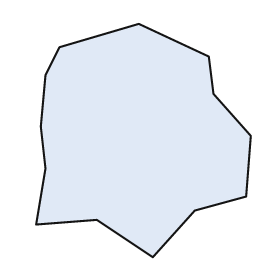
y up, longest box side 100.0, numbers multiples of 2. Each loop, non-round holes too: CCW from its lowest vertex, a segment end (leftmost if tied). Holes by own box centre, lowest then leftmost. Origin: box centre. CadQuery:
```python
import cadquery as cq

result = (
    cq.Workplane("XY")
    .moveTo(4.0, -50.0)
    .lineTo(22.0, -30.0)
    .lineTo(44.0, -24.0)
    .lineTo(46.0, 2.0)
    .lineTo(30.0, 20.0)
    .lineTo(28.0, 36.0)
    .lineTo(-2.0, 50.0)
    .lineTo(-36.0, 40.0)
    .lineTo(-42.0, 28.0)
    .lineTo(-44.0, 6.0)
    .lineTo(-42.0, -12.0)
    .lineTo(-46.0, -36.0)
    .lineTo(-20.0, -34.0)
    .close()
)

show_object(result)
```